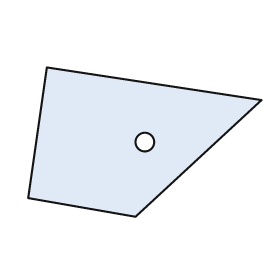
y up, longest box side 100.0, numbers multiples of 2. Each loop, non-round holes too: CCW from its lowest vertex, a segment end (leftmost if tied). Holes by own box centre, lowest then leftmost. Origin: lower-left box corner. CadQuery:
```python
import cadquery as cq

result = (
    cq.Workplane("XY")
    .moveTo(46.0, 0.0)
    .lineTo(100.0, 50.0)
    .lineTo(8.0, 64.0)
    .lineTo(0.0, 8.0)
    .close()
    .moveTo(50.0, 32.0)
    .circle(4.0)
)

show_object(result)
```